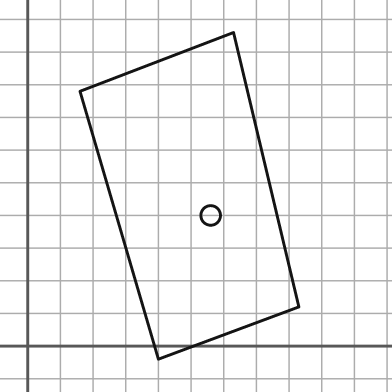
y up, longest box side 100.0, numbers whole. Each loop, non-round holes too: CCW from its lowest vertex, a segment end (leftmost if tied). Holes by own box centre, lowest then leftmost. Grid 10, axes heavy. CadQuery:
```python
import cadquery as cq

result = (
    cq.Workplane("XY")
    .moveTo(40.0, -4.0)
    .lineTo(83.0, 12.0)
    .lineTo(63.0, 96.0)
    .lineTo(16.0, 78.0)
    .close()
    .moveTo(56.0, 40.0)
    .circle(3.0)
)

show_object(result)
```